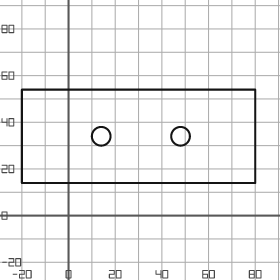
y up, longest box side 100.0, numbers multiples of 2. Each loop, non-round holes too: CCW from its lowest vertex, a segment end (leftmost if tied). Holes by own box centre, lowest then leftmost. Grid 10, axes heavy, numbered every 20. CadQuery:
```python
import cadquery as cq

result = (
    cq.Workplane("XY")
    .moveTo(-20.0, 14.0)
    .lineTo(80.0, 14.0)
    .lineTo(80.0, 54.0)
    .lineTo(-20.0, 54.0)
    .close()
    .moveTo(14.0, 34.0)
    .circle(4.0)
    .moveTo(48.0, 34.0)
    .circle(4.0)
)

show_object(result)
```